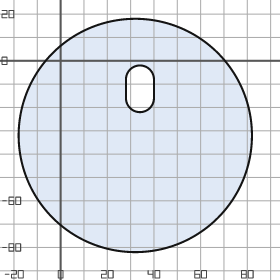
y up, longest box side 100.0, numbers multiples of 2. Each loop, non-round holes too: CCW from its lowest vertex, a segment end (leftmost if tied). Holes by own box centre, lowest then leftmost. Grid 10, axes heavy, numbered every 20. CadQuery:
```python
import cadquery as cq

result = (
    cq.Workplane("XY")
    .moveTo(32.0, -32.0)
    .circle(50.0)
    .moveTo(28.0, -16.0)
    .threePointArc((34.0, -22.0), (40.0, -16.0))
    .lineTo(40.0, -8.0)
    .threePointArc((34.0, -2.0), (28.0, -8.0))
    .close()
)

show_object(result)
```